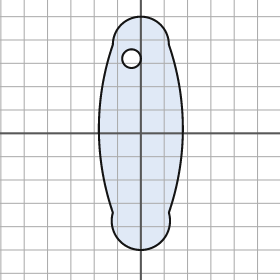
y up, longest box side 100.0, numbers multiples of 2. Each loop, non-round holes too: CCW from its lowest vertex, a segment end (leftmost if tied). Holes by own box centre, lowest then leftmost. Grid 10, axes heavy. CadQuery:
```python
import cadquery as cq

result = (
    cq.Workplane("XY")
    .moveTo(-12.0, -34.0)
    .threePointArc((0.0, -50.0), (12.0, -34.0))
    .threePointArc((18.0, 2.0), (12.0, 38.0))
    .threePointArc((0.0, 50.0), (-12.0, 38.0))
    .threePointArc((-18.0, 2.0), (-12.0, -34.0))
    .close()
    .moveTo(-4.0, 32.0)
    .circle(4.0)
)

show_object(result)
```